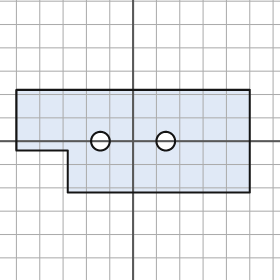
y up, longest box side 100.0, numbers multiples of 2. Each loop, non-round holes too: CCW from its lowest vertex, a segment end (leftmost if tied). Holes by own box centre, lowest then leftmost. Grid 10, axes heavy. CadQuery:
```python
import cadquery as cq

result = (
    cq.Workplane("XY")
    .moveTo(-28.0, -22.0)
    .lineTo(50.0, -22.0)
    .lineTo(50.0, 22.0)
    .lineTo(-50.0, 22.0)
    .lineTo(-50.0, -4.0)
    .lineTo(-28.0, -4.0)
    .close()
    .moveTo(-14.0, 0.0)
    .circle(4.0)
    .moveTo(14.0, 0.0)
    .circle(4.0)
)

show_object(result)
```